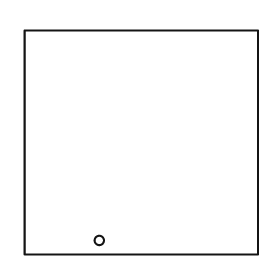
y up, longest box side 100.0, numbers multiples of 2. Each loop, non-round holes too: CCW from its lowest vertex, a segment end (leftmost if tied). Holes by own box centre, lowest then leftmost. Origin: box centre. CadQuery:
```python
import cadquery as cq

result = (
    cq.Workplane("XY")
    .moveTo(-50.0, -48.0)
    .lineTo(50.0, -48.0)
    .lineTo(50.0, 48.0)
    .lineTo(-50.0, 48.0)
    .close()
    .moveTo(-18.0, -42.0)
    .circle(2.0)
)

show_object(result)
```